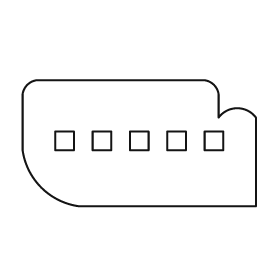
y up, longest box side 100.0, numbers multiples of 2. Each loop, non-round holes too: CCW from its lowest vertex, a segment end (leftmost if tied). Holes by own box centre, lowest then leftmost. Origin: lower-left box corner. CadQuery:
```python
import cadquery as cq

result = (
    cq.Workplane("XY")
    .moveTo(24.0, 0.0)
    .lineTo(100.0, 0.0)
    .lineTo(100.0, 38.0)
    .threePointArc((92.0, 42.0), (84.0, 38.0))
    .lineTo(84.0, 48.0)
    .threePointArc((82.0, 52.0), (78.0, 54.0))
    .lineTo(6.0, 54.0)
    .threePointArc((2.0, 52.0), (0.0, 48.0))
    .lineTo(0.0, 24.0)
    .threePointArc((8.0, 8.0), (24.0, 0.0))
    .close()
    .moveTo(14.0, 24.0)
    .lineTo(22.0, 24.0)
    .lineTo(22.0, 32.0)
    .lineTo(14.0, 32.0)
    .close()
    .moveTo(30.0, 24.0)
    .lineTo(38.0, 24.0)
    .lineTo(38.0, 32.0)
    .lineTo(30.0, 32.0)
    .close()
    .moveTo(46.0, 24.0)
    .lineTo(54.0, 24.0)
    .lineTo(54.0, 32.0)
    .lineTo(46.0, 32.0)
    .close()
    .moveTo(62.0, 24.0)
    .lineTo(70.0, 24.0)
    .lineTo(70.0, 32.0)
    .lineTo(62.0, 32.0)
    .close()
    .moveTo(78.0, 24.0)
    .lineTo(86.0, 24.0)
    .lineTo(86.0, 32.0)
    .lineTo(78.0, 32.0)
    .close()
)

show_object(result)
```